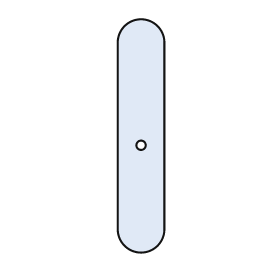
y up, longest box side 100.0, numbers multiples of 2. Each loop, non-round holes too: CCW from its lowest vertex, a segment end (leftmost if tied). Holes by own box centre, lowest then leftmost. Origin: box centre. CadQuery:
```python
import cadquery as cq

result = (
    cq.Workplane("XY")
    .moveTo(-10.0, -40.0)
    .threePointArc((0.0, -50.0), (10.0, -40.0))
    .lineTo(10.0, 40.0)
    .threePointArc((0.0, 50.0), (-10.0, 40.0))
    .close()
    .moveTo(0.0, -4.0)
    .circle(2.0)
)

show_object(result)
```